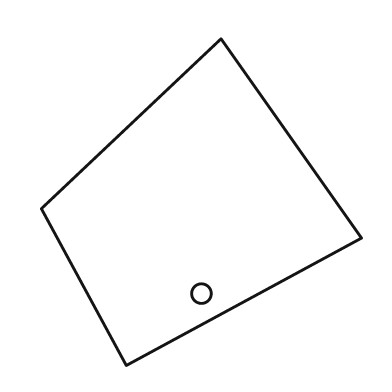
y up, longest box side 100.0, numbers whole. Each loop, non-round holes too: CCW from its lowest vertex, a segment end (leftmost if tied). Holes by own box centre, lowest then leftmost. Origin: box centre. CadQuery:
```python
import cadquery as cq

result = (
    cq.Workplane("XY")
    .moveTo(-23.0, -50.0)
    .lineTo(49.0, -11.0)
    .lineTo(6.0, 50.0)
    .lineTo(-49.0, -2.0)
    .close()
    .moveTo(0.0, -28.0)
    .circle(3.0)
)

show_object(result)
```